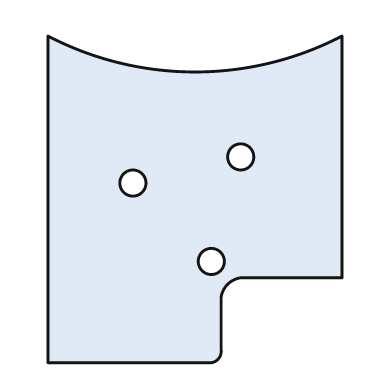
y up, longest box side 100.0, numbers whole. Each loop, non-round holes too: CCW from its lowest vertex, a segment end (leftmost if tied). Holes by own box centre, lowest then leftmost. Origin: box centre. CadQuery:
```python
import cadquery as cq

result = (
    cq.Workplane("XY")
    .moveTo(-45.0, -50.0)
    .lineTo(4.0, -50.0)
    .threePointArc((7.0, -49.0), (8.0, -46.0))
    .lineTo(8.0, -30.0)
    .threePointArc((10.0, -26.0), (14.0, -24.0))
    .lineTo(45.0, -24.0)
    .lineTo(45.0, 50.0)
    .threePointArc((0.0, 39.0), (-45.0, 50.0))
    .close()
    .moveTo(5.0, -19.0)
    .circle(4.0)
    .moveTo(-19.0, 5.0)
    .circle(4.0)
    .moveTo(14.0, 13.0)
    .circle(4.0)
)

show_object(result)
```